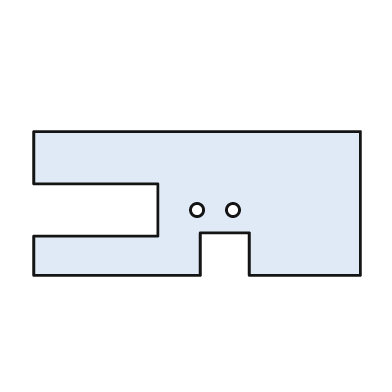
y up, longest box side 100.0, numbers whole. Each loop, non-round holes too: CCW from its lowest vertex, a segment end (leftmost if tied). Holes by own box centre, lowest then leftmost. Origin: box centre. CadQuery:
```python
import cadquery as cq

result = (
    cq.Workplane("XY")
    .moveTo(-50.0, -22.0)
    .lineTo(1.0, -22.0)
    .lineTo(1.0, -9.0)
    .lineTo(16.0, -9.0)
    .lineTo(16.0, -22.0)
    .lineTo(50.0, -22.0)
    .lineTo(50.0, 22.0)
    .lineTo(-50.0, 22.0)
    .lineTo(-50.0, 6.0)
    .lineTo(-12.0, 6.0)
    .lineTo(-12.0, -10.0)
    .lineTo(-50.0, -10.0)
    .close()
    .moveTo(0.0, -2.0)
    .circle(2.0)
    .moveTo(11.0, -2.0)
    .circle(2.0)
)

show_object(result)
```